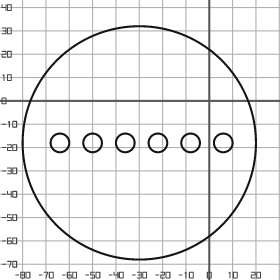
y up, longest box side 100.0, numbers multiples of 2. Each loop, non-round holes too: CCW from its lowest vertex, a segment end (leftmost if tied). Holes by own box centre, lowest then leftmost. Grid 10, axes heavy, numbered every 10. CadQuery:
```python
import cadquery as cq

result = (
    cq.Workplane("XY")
    .moveTo(-30.0, -18.0)
    .circle(50.0)
    .moveTo(-64.0, -18.0)
    .circle(4.0)
    .moveTo(-50.0, -18.0)
    .circle(4.0)
    .moveTo(-36.0, -18.0)
    .circle(4.0)
    .moveTo(-22.0, -18.0)
    .circle(4.0)
    .moveTo(-8.0, -18.0)
    .circle(4.0)
    .moveTo(6.0, -18.0)
    .circle(4.0)
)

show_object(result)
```